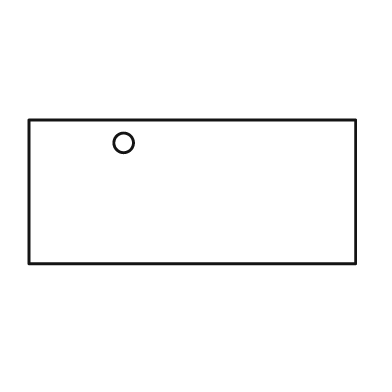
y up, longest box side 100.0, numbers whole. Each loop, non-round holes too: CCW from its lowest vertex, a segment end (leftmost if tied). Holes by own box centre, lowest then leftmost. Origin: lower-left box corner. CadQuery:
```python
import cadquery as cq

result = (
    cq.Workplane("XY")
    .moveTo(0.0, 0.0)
    .lineTo(100.0, 0.0)
    .lineTo(100.0, 44.0)
    .lineTo(0.0, 44.0)
    .close()
    .moveTo(29.0, 37.0)
    .circle(3.0)
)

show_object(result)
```